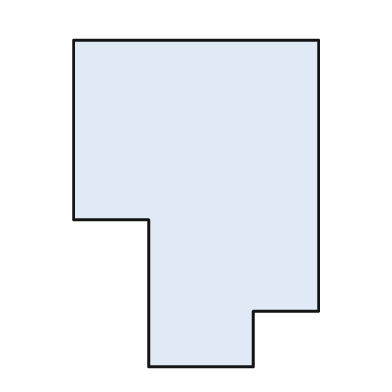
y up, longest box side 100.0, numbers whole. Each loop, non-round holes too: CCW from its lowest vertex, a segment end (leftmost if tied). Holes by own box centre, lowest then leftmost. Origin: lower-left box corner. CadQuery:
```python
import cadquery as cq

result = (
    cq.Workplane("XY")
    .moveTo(23.0, 0.0)
    .lineTo(55.0, 0.0)
    .lineTo(55.0, 17.0)
    .lineTo(75.0, 17.0)
    .lineTo(75.0, 100.0)
    .lineTo(0.0, 100.0)
    .lineTo(0.0, 45.0)
    .lineTo(23.0, 45.0)
    .close()
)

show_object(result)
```